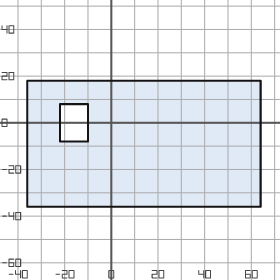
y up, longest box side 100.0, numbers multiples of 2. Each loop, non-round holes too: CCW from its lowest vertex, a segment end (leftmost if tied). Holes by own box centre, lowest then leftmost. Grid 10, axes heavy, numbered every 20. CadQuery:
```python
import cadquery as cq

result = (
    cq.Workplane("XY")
    .moveTo(-36.0, -36.0)
    .lineTo(64.0, -36.0)
    .lineTo(64.0, 18.0)
    .lineTo(-36.0, 18.0)
    .close()
    .moveTo(-22.0, -8.0)
    .lineTo(-10.0, -8.0)
    .lineTo(-10.0, 8.0)
    .lineTo(-22.0, 8.0)
    .close()
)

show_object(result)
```